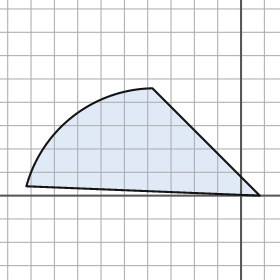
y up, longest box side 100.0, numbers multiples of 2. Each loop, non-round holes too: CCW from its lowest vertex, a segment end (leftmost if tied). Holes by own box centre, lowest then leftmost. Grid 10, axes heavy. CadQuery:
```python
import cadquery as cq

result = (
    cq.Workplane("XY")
    .moveTo(8.0, 0.0)
    .lineTo(-38.0, 46.0)
    .threePointArc((-72.0, 34.0), (-92.0, 4.0))
    .close()
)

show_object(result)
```